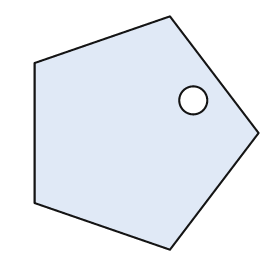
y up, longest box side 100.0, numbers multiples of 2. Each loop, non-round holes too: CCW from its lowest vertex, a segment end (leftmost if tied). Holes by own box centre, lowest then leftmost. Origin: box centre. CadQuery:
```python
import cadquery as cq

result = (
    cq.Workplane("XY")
    .moveTo(10.0, -50.0)
    .lineTo(48.0, 0.0)
    .lineTo(10.0, 50.0)
    .lineTo(-48.0, 30.0)
    .lineTo(-48.0, -30.0)
    .close()
    .moveTo(20.0, 14.0)
    .circle(6.0)
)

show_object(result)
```